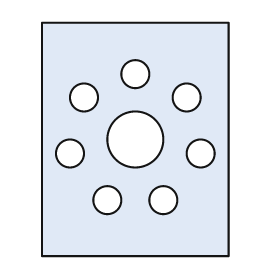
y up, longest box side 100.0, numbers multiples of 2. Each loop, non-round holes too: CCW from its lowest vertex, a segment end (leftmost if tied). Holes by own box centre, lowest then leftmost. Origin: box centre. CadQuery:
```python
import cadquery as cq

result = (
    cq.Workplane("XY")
    .moveTo(-40.0, -50.0)
    .lineTo(40.0, -50.0)
    .lineTo(40.0, 50.0)
    .lineTo(-40.0, 50.0)
    .close()
    .moveTo(-12.0, -26.0)
    .circle(6.0)
    .moveTo(12.0, -26.0)
    .circle(6.0)
    .moveTo(-28.0, -6.0)
    .circle(6.0)
    .moveTo(28.0, -6.0)
    .circle(6.0)
    .moveTo(0.0, 0.0)
    .circle(12.0)
    .moveTo(-22.0, 18.0)
    .circle(6.0)
    .moveTo(22.0, 18.0)
    .circle(6.0)
    .moveTo(0.0, 28.0)
    .circle(6.0)
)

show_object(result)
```